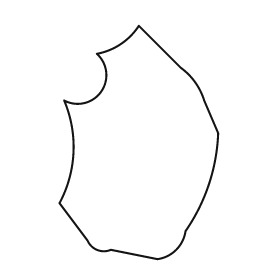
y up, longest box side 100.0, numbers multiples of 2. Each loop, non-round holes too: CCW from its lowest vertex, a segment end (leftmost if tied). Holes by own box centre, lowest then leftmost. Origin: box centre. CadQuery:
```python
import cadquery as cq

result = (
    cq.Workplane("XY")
    .moveTo(8.0, -50.0)
    .threePointArc((16.0, -46.0), (20.0, -38.0))
    .threePointArc((30.0, -18.0), (34.0, 4.0))
    .lineTo(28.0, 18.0)
    .threePointArc((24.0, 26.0), (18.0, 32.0))
    .lineTo(0.0, 50.0)
    .threePointArc((-8.0, 42.0), (-18.0, 38.0))
    .threePointArc((-16.0, 22.0), (-32.0, 18.0))
    .threePointArc((-28.0, -4.0), (-34.0, -26.0))
    .lineTo(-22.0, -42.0)
    .threePointArc((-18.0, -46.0), (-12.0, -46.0))
    .close()
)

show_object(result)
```